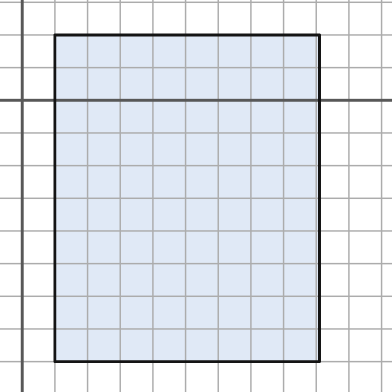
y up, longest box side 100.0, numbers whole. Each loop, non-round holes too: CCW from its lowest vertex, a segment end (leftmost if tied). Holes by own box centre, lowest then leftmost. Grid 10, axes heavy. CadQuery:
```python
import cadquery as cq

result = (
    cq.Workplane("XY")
    .moveTo(10.0, -80.0)
    .lineTo(91.0, -80.0)
    .lineTo(91.0, 20.0)
    .lineTo(10.0, 20.0)
    .close()
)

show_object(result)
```